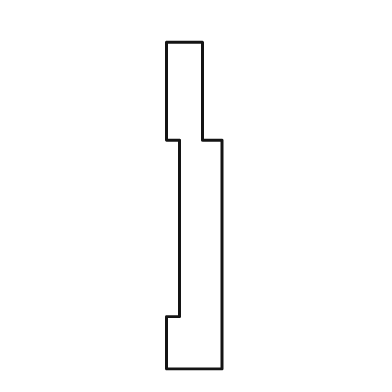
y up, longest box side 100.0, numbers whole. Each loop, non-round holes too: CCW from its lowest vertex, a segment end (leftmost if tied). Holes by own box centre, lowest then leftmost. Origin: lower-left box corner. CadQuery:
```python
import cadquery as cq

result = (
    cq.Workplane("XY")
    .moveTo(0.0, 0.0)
    .lineTo(17.0, 0.0)
    .lineTo(17.0, 70.0)
    .lineTo(11.0, 70.0)
    .lineTo(11.0, 100.0)
    .lineTo(0.0, 100.0)
    .lineTo(0.0, 70.0)
    .lineTo(4.0, 70.0)
    .lineTo(4.0, 16.0)
    .lineTo(0.0, 16.0)
    .close()
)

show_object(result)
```